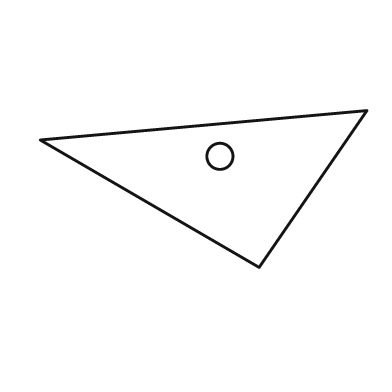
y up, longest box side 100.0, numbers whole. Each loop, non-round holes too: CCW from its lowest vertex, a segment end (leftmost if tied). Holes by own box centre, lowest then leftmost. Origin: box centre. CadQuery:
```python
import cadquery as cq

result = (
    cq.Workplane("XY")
    .moveTo(17.0, -24.0)
    .lineTo(50.0, 24.0)
    .lineTo(-50.0, 15.0)
    .close()
    .moveTo(5.0, 10.0)
    .circle(4.0)
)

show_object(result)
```